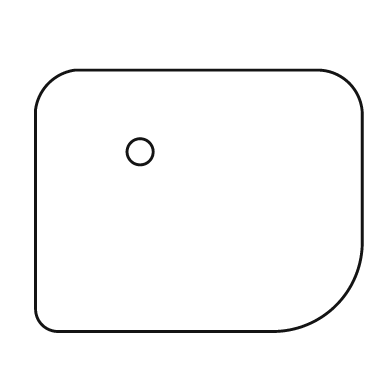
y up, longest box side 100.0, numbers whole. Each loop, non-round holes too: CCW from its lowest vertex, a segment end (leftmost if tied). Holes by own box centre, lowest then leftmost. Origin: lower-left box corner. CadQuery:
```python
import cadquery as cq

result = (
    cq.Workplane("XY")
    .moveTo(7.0, 0.0)
    .lineTo(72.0, 0.0)
    .threePointArc((92.0, 8.0), (100.0, 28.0))
    .lineTo(100.0, 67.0)
    .threePointArc((96.0, 76.0), (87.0, 80.0))
    .lineTo(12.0, 80.0)
    .threePointArc((4.0, 76.0), (0.0, 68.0))
    .lineTo(0.0, 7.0)
    .threePointArc((2.0, 2.0), (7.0, 0.0))
    .close()
    .moveTo(32.0, 55.0)
    .circle(4.0)
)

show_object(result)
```